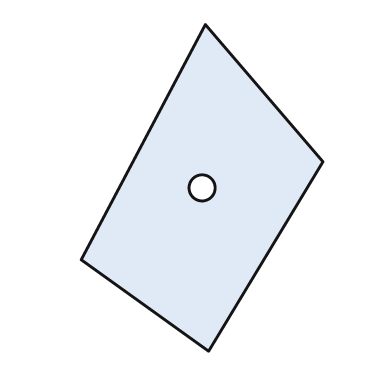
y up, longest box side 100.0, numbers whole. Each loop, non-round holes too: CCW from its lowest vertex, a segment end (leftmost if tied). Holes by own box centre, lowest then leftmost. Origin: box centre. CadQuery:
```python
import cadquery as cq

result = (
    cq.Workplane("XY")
    .moveTo(2.0, -50.0)
    .lineTo(37.0, 8.0)
    .lineTo(1.0, 50.0)
    .lineTo(-37.0, -22.0)
    .close()
    .moveTo(0.0, 0.0)
    .circle(4.0)
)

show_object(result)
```